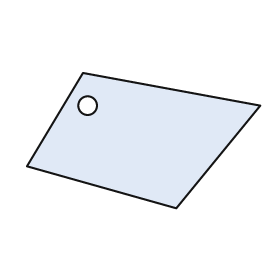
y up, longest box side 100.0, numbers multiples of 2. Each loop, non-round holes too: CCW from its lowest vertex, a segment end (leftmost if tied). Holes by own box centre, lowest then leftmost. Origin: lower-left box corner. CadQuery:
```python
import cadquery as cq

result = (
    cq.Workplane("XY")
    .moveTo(64.0, 0.0)
    .lineTo(100.0, 44.0)
    .lineTo(24.0, 58.0)
    .lineTo(0.0, 18.0)
    .close()
    .moveTo(26.0, 44.0)
    .circle(4.0)
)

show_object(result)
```